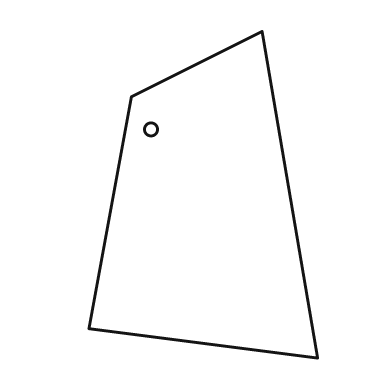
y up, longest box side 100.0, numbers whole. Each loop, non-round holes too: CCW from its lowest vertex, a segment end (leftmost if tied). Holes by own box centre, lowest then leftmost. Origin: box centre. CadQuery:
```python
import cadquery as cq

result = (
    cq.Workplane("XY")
    .moveTo(35.0, -50.0)
    .lineTo(18.0, 50.0)
    .lineTo(-22.0, 30.0)
    .lineTo(-35.0, -41.0)
    .close()
    .moveTo(-16.0, 20.0)
    .circle(2.0)
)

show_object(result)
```